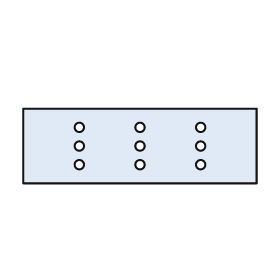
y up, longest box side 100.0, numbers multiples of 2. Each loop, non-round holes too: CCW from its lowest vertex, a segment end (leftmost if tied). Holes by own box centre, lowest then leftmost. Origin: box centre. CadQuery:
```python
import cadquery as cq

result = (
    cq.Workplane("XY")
    .moveTo(-50.0, -16.0)
    .lineTo(50.0, -16.0)
    .lineTo(50.0, 16.0)
    .lineTo(-50.0, 16.0)
    .close()
    .moveTo(-26.0, -8.0)
    .circle(2.0)
    .moveTo(0.0, -8.0)
    .circle(2.0)
    .moveTo(26.0, -8.0)
    .circle(2.0)
    .moveTo(-26.0, 0.0)
    .circle(2.0)
    .moveTo(0.0, 0.0)
    .circle(2.0)
    .moveTo(26.0, 0.0)
    .circle(2.0)
    .moveTo(-26.0, 8.0)
    .circle(2.0)
    .moveTo(0.0, 8.0)
    .circle(2.0)
    .moveTo(26.0, 8.0)
    .circle(2.0)
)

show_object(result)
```